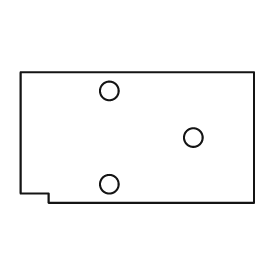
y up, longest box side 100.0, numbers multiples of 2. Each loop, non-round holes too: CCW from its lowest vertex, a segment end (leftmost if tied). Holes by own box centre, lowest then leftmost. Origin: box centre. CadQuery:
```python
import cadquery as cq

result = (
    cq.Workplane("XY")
    .moveTo(-38.0, -28.0)
    .lineTo(50.0, -28.0)
    .lineTo(50.0, 28.0)
    .lineTo(-50.0, 28.0)
    .lineTo(-50.0, -24.0)
    .lineTo(-38.0, -24.0)
    .close()
    .moveTo(-12.0, -20.0)
    .circle(4.0)
    .moveTo(24.0, 0.0)
    .circle(4.0)
    .moveTo(-12.0, 20.0)
    .circle(4.0)
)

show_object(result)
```